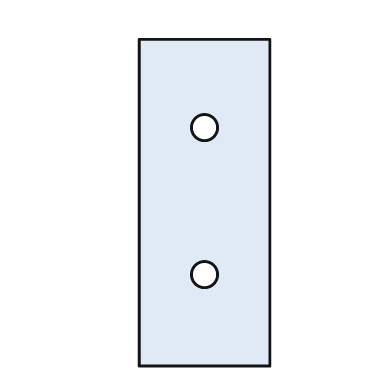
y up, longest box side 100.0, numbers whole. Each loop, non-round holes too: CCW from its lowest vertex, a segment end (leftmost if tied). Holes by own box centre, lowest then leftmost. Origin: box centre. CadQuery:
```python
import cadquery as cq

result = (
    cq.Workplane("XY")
    .moveTo(-20.0, -50.0)
    .lineTo(20.0, -50.0)
    .lineTo(20.0, 50.0)
    .lineTo(-20.0, 50.0)
    .close()
    .moveTo(0.0, -22.0)
    .circle(4.0)
    .moveTo(0.0, 23.0)
    .circle(4.0)
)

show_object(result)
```